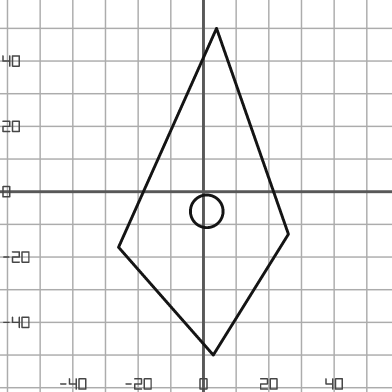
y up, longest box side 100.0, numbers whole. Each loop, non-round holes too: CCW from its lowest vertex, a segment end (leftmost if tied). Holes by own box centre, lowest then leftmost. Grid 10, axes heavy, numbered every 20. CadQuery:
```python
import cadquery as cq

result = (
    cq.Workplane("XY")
    .moveTo(3.0, -50.0)
    .lineTo(26.0, -13.0)
    .lineTo(4.0, 50.0)
    .lineTo(-26.0, -17.0)
    .close()
    .moveTo(1.0, -6.0)
    .circle(5.0)
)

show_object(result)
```